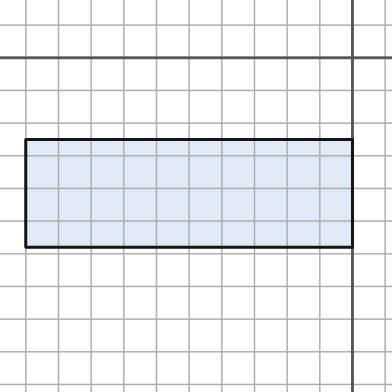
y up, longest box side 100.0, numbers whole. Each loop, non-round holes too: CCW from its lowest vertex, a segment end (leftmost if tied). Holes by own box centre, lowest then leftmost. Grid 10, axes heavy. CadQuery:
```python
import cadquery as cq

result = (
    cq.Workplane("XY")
    .moveTo(-100.0, -58.0)
    .lineTo(0.0, -58.0)
    .lineTo(0.0, -25.0)
    .lineTo(-100.0, -25.0)
    .close()
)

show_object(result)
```